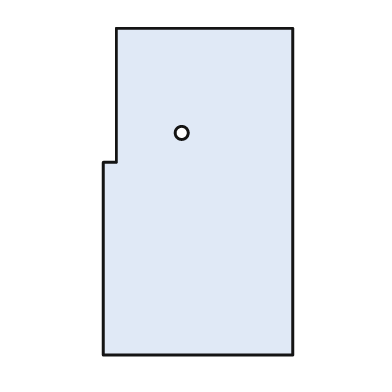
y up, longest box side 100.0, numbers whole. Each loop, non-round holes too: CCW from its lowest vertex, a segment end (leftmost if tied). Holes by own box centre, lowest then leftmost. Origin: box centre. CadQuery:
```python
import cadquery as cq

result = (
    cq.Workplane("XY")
    .moveTo(-29.0, -50.0)
    .lineTo(29.0, -50.0)
    .lineTo(29.0, 50.0)
    .lineTo(-25.0, 50.0)
    .lineTo(-25.0, 9.0)
    .lineTo(-29.0, 9.0)
    .close()
    .moveTo(-5.0, 18.0)
    .circle(2.0)
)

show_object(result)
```